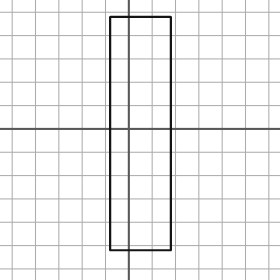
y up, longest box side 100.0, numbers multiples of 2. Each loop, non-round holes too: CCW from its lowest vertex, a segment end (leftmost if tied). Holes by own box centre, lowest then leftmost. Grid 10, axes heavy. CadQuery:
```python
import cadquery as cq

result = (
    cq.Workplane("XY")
    .moveTo(-8.0, -52.0)
    .lineTo(18.0, -52.0)
    .lineTo(18.0, 48.0)
    .lineTo(-8.0, 48.0)
    .close()
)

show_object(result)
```